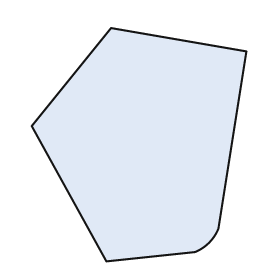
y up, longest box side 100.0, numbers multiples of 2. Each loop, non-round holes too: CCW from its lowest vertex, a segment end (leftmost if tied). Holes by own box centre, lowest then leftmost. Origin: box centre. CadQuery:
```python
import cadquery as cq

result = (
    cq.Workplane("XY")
    .moveTo(-14.0, -50.0)
    .lineTo(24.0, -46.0)
    .threePointArc((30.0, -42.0), (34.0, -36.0))
    .lineTo(46.0, 40.0)
    .lineTo(-12.0, 50.0)
    .lineTo(-46.0, 8.0)
    .close()
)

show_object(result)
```